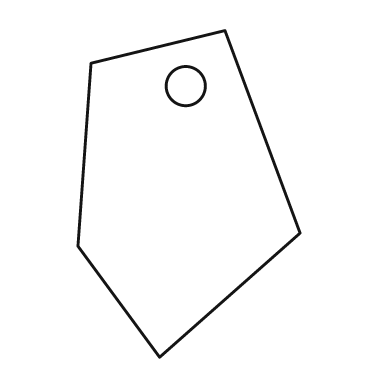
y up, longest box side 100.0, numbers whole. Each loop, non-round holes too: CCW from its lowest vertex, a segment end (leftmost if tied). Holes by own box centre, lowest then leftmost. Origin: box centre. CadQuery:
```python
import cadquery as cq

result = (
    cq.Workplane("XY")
    .moveTo(-9.0, -50.0)
    .lineTo(34.0, -12.0)
    .lineTo(11.0, 50.0)
    .lineTo(-30.0, 40.0)
    .lineTo(-34.0, -16.0)
    .close()
    .moveTo(-1.0, 33.0)
    .circle(6.0)
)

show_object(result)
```